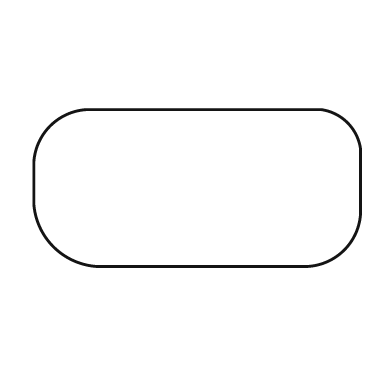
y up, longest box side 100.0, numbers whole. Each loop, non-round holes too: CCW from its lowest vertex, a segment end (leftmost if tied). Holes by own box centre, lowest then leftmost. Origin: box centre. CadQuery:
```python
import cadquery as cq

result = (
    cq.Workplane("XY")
    .moveTo(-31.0, -24.0)
    .lineTo(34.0, -24.0)
    .threePointArc((45.0, -19.0), (50.0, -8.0))
    .lineTo(50.0, 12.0)
    .threePointArc((46.0, 20.0), (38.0, 24.0))
    .lineTo(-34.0, 24.0)
    .threePointArc((-45.0, 19.0), (-50.0, 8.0))
    .lineTo(-50.0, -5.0)
    .threePointArc((-44.0, -18.0), (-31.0, -24.0))
    .close()
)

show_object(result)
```